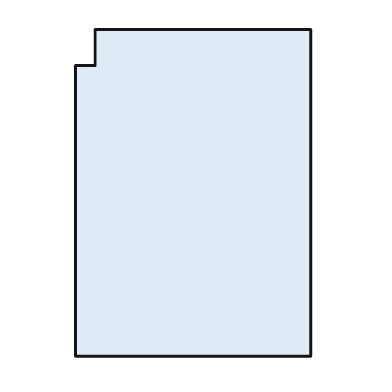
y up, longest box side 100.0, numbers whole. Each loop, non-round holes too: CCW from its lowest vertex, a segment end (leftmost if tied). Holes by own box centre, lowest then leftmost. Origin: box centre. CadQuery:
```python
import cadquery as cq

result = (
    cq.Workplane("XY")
    .moveTo(-36.0, -50.0)
    .lineTo(36.0, -50.0)
    .lineTo(36.0, 50.0)
    .lineTo(-30.0, 50.0)
    .lineTo(-30.0, 39.0)
    .lineTo(-36.0, 39.0)
    .close()
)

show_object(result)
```